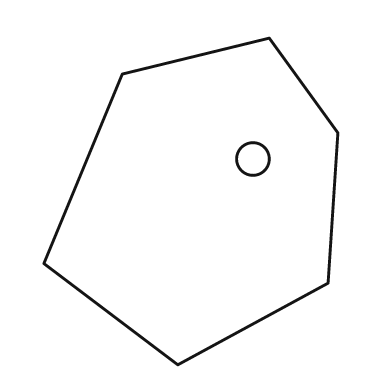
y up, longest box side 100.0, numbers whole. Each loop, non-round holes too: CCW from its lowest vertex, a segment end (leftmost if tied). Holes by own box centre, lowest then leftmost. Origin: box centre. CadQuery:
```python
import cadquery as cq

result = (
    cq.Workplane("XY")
    .moveTo(-4.0, -50.0)
    .lineTo(42.0, -25.0)
    .lineTo(45.0, 21.0)
    .lineTo(24.0, 50.0)
    .lineTo(-21.0, 39.0)
    .lineTo(-45.0, -19.0)
    .close()
    .moveTo(19.0, 13.0)
    .circle(5.0)
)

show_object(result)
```